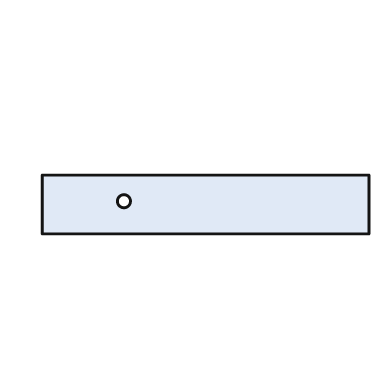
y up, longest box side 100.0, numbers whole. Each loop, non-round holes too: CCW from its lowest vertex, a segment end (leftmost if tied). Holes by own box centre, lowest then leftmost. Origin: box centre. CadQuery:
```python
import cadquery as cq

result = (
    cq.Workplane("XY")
    .moveTo(-50.0, -9.0)
    .lineTo(50.0, -9.0)
    .lineTo(50.0, 9.0)
    .lineTo(-50.0, 9.0)
    .close()
    .moveTo(-25.0, 1.0)
    .circle(2.0)
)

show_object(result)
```